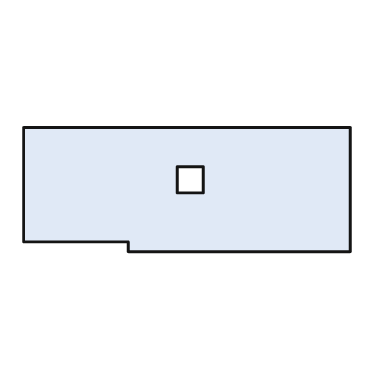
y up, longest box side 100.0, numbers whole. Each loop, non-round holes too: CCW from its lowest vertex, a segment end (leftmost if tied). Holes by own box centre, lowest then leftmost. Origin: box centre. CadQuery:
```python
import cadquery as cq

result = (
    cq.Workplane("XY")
    .moveTo(-18.0, -19.0)
    .lineTo(50.0, -19.0)
    .lineTo(50.0, 19.0)
    .lineTo(-50.0, 19.0)
    .lineTo(-50.0, -16.0)
    .lineTo(-18.0, -16.0)
    .close()
    .moveTo(-3.0, -1.0)
    .lineTo(5.0, -1.0)
    .lineTo(5.0, 7.0)
    .lineTo(-3.0, 7.0)
    .close()
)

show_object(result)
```